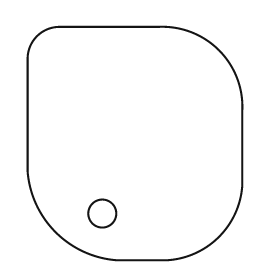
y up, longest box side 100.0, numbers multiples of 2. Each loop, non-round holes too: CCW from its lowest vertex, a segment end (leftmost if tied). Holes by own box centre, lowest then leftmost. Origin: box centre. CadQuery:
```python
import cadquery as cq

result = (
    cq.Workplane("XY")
    .moveTo(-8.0, -50.0)
    .lineTo(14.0, -50.0)
    .threePointArc((36.0, -40.0), (46.0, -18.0))
    .lineTo(46.0, 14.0)
    .threePointArc((36.0, 40.0), (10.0, 50.0))
    .lineTo(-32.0, 50.0)
    .threePointArc((-42.0, 46.0), (-46.0, 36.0))
    .lineTo(-46.0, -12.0)
    .threePointArc((-34.0, -38.0), (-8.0, -50.0))
    .close()
    .moveTo(-14.0, -30.0)
    .circle(6.0)
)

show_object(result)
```